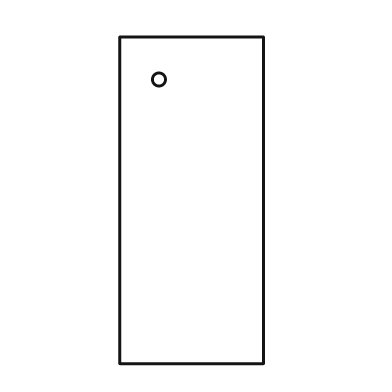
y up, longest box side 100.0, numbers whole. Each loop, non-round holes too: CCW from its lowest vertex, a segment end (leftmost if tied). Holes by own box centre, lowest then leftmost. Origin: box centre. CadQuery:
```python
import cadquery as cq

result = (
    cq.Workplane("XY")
    .moveTo(-22.0, -50.0)
    .lineTo(22.0, -50.0)
    .lineTo(22.0, 50.0)
    .lineTo(-22.0, 50.0)
    .close()
    .moveTo(-10.0, 37.0)
    .circle(2.0)
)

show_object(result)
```